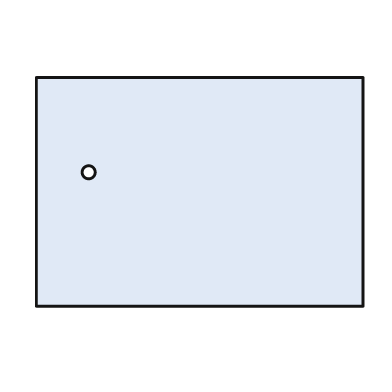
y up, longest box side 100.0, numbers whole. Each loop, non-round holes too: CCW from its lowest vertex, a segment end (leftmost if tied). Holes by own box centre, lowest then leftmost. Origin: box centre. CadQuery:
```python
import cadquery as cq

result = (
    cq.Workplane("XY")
    .moveTo(-50.0, -35.0)
    .lineTo(50.0, -35.0)
    .lineTo(50.0, 35.0)
    .lineTo(-50.0, 35.0)
    .close()
    .moveTo(-34.0, 6.0)
    .circle(2.0)
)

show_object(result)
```